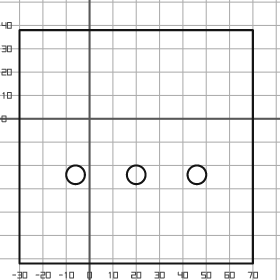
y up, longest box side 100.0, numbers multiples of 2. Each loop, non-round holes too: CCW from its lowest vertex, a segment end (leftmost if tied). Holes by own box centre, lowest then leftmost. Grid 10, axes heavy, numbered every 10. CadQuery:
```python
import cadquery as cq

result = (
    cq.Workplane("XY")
    .moveTo(-30.0, -62.0)
    .lineTo(70.0, -62.0)
    .lineTo(70.0, 38.0)
    .lineTo(-30.0, 38.0)
    .close()
    .moveTo(-6.0, -24.0)
    .circle(4.0)
    .moveTo(20.0, -24.0)
    .circle(4.0)
    .moveTo(46.0, -24.0)
    .circle(4.0)
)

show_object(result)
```